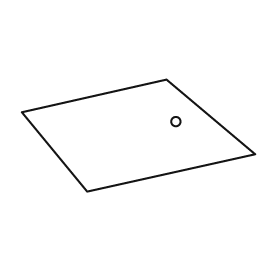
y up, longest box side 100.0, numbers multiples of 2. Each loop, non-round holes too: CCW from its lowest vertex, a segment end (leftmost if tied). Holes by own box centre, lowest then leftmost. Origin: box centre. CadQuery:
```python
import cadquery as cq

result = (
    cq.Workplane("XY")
    .moveTo(-22.0, -24.0)
    .lineTo(50.0, -8.0)
    .lineTo(12.0, 24.0)
    .lineTo(-50.0, 10.0)
    .close()
    .moveTo(16.0, 6.0)
    .circle(2.0)
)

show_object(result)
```